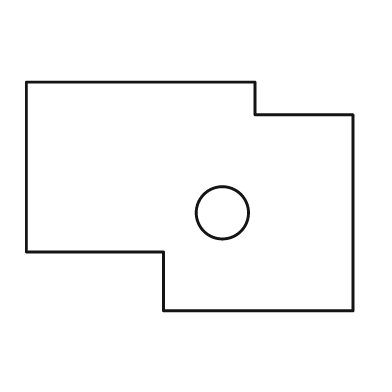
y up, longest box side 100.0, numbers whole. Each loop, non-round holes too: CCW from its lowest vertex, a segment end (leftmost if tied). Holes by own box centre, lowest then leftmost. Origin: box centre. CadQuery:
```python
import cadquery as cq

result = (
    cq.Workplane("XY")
    .moveTo(-8.0, -35.0)
    .lineTo(50.0, -35.0)
    .lineTo(50.0, 25.0)
    .lineTo(20.0, 25.0)
    .lineTo(20.0, 35.0)
    .lineTo(-50.0, 35.0)
    .lineTo(-50.0, -17.0)
    .lineTo(-8.0, -17.0)
    .close()
    .moveTo(10.0, -5.0)
    .circle(8.0)
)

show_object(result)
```